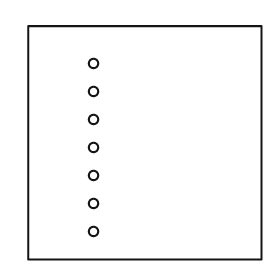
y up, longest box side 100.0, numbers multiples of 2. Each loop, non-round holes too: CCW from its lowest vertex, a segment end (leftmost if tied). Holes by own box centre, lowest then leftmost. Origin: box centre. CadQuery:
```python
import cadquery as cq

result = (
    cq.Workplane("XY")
    .moveTo(-50.0, -50.0)
    .lineTo(50.0, -50.0)
    .lineTo(50.0, 50.0)
    .lineTo(-50.0, 50.0)
    .close()
    .moveTo(-22.0, -38.0)
    .circle(2.0)
    .moveTo(-22.0, -26.0)
    .circle(2.0)
    .moveTo(-22.0, -14.0)
    .circle(2.0)
    .moveTo(-22.0, -2.0)
    .circle(2.0)
    .moveTo(-22.0, 10.0)
    .circle(2.0)
    .moveTo(-22.0, 22.0)
    .circle(2.0)
    .moveTo(-22.0, 34.0)
    .circle(2.0)
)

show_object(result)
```